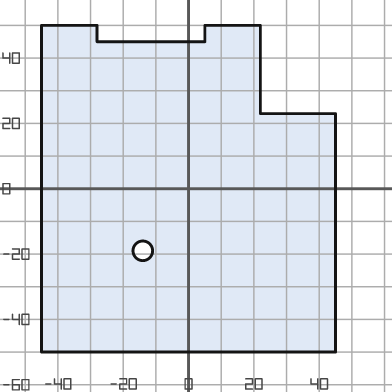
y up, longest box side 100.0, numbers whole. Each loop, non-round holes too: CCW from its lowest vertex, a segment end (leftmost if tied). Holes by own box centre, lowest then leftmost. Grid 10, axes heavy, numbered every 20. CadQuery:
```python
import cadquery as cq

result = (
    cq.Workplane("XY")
    .moveTo(-45.0, -50.0)
    .lineTo(45.0, -50.0)
    .lineTo(45.0, 23.0)
    .lineTo(22.0, 23.0)
    .lineTo(22.0, 50.0)
    .lineTo(5.0, 50.0)
    .lineTo(5.0, 45.0)
    .lineTo(-28.0, 45.0)
    .lineTo(-28.0, 50.0)
    .lineTo(-45.0, 50.0)
    .close()
    .moveTo(-14.0, -19.0)
    .circle(3.0)
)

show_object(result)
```